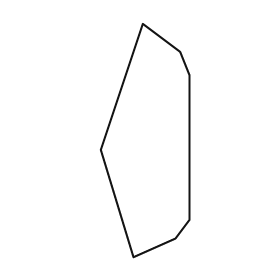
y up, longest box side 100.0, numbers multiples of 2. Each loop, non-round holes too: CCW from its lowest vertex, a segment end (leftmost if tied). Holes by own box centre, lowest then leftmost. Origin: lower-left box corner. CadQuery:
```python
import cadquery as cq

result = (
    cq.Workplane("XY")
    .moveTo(14.0, 0.0)
    .lineTo(32.0, 8.0)
    .lineTo(38.0, 16.0)
    .lineTo(38.0, 78.0)
    .lineTo(34.0, 88.0)
    .lineTo(18.0, 100.0)
    .lineTo(0.0, 46.0)
    .close()
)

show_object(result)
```